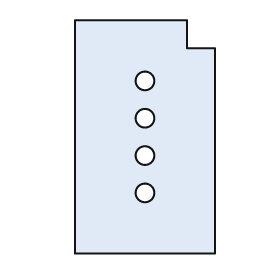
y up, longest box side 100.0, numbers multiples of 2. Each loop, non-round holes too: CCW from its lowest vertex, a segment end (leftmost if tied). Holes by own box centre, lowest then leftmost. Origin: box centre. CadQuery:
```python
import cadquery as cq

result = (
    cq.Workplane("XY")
    .moveTo(-30.0, -50.0)
    .lineTo(30.0, -50.0)
    .lineTo(30.0, 38.0)
    .lineTo(18.0, 38.0)
    .lineTo(18.0, 50.0)
    .lineTo(-30.0, 50.0)
    .close()
    .moveTo(0.0, -24.0)
    .circle(4.0)
    .moveTo(0.0, -8.0)
    .circle(4.0)
    .moveTo(0.0, 8.0)
    .circle(4.0)
    .moveTo(0.0, 24.0)
    .circle(4.0)
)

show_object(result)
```